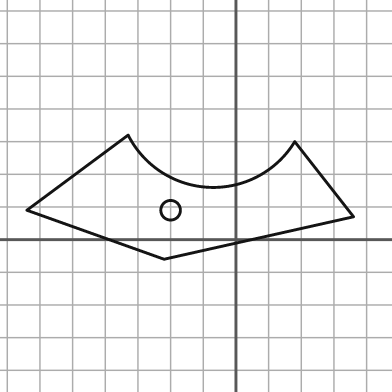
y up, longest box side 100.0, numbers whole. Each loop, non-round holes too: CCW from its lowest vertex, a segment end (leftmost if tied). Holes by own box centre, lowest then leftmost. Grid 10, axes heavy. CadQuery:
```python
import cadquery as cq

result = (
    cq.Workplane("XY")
    .moveTo(-22.0, -6.0)
    .lineTo(36.0, 7.0)
    .lineTo(18.0, 30.0)
    .threePointArc((-8.0, 16.0), (-33.0, 32.0))
    .lineTo(-64.0, 9.0)
    .close()
    .moveTo(-20.0, 9.0)
    .circle(3.0)
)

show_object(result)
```